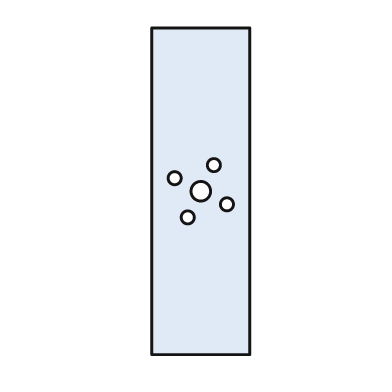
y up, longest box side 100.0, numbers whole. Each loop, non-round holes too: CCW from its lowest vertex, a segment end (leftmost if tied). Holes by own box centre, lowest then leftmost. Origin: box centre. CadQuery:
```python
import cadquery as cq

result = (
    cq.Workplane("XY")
    .moveTo(-15.0, -50.0)
    .lineTo(15.0, -50.0)
    .lineTo(15.0, 50.0)
    .lineTo(-15.0, 50.0)
    .close()
    .moveTo(-4.0, -8.0)
    .circle(2.0)
    .moveTo(8.0, -4.0)
    .circle(2.0)
    .moveTo(0.0, 0.0)
    .circle(3.0)
    .moveTo(-8.0, 4.0)
    .circle(2.0)
    .moveTo(4.0, 8.0)
    .circle(2.0)
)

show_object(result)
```